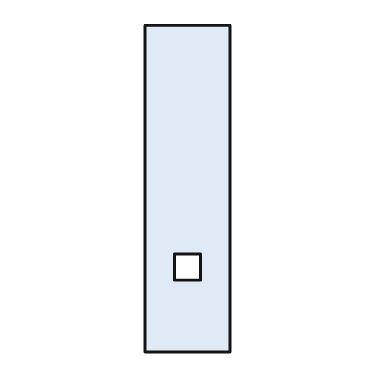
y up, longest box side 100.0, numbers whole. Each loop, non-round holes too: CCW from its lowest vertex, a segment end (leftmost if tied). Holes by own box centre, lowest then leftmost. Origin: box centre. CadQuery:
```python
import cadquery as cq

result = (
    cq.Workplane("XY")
    .moveTo(-13.0, -50.0)
    .lineTo(13.0, -50.0)
    .lineTo(13.0, 50.0)
    .lineTo(-13.0, 50.0)
    .close()
    .moveTo(-4.0, -28.0)
    .lineTo(4.0, -28.0)
    .lineTo(4.0, -20.0)
    .lineTo(-4.0, -20.0)
    .close()
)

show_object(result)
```